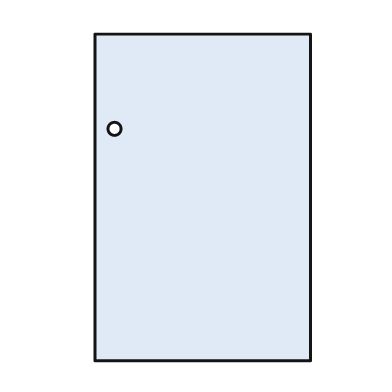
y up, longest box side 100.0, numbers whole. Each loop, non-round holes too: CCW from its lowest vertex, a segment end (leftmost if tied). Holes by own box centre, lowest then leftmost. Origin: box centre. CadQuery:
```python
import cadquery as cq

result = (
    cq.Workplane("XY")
    .moveTo(-33.0, -50.0)
    .lineTo(33.0, -50.0)
    .lineTo(33.0, 50.0)
    .lineTo(-33.0, 50.0)
    .close()
    .moveTo(-27.0, 21.0)
    .circle(2.0)
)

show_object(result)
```